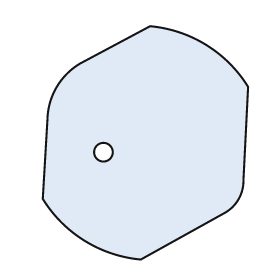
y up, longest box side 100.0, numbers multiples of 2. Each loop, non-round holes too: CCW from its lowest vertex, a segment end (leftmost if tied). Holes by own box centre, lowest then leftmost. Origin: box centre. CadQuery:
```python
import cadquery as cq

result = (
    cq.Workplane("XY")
    .moveTo(-2.0, -50.0)
    .lineTo(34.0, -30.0)
    .threePointArc((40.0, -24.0), (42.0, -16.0))
    .lineTo(44.0, 24.0)
    .threePointArc((26.0, 42.0), (2.0, 50.0))
    .lineTo(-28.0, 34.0)
    .threePointArc((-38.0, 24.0), (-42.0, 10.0))
    .lineTo(-44.0, -24.0)
    .threePointArc((-26.0, -42.0), (-2.0, -50.0))
    .close()
    .moveTo(-18.0, -4.0)
    .circle(4.0)
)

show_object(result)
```